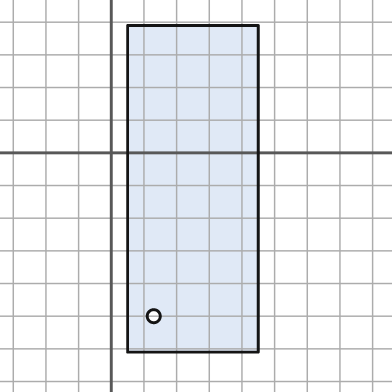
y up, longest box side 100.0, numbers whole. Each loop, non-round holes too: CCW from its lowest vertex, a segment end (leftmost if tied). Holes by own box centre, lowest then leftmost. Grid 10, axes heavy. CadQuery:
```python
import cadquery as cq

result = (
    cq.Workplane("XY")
    .moveTo(5.0, -61.0)
    .lineTo(45.0, -61.0)
    .lineTo(45.0, 39.0)
    .lineTo(5.0, 39.0)
    .close()
    .moveTo(13.0, -50.0)
    .circle(2.0)
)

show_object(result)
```